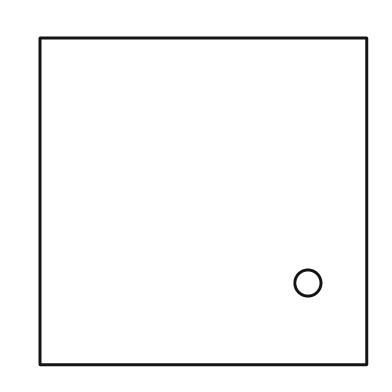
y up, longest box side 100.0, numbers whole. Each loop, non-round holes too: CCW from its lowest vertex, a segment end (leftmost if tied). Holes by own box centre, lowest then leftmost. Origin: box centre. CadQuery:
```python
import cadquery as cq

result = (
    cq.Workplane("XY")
    .moveTo(-50.0, -50.0)
    .lineTo(50.0, -50.0)
    .lineTo(50.0, 50.0)
    .lineTo(-50.0, 50.0)
    .close()
    .moveTo(32.0, -25.0)
    .circle(4.0)
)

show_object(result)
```